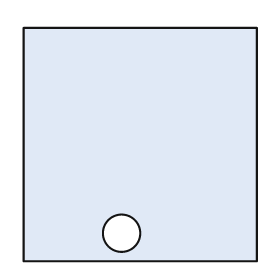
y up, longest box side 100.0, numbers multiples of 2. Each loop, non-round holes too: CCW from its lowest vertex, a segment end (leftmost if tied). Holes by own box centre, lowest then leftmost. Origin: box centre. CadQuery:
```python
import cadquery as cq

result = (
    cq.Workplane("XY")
    .moveTo(-50.0, -50.0)
    .lineTo(50.0, -50.0)
    .lineTo(50.0, 50.0)
    .lineTo(-50.0, 50.0)
    .close()
    .moveTo(-8.0, -38.0)
    .circle(8.0)
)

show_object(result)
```